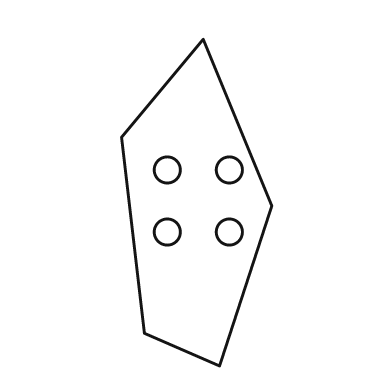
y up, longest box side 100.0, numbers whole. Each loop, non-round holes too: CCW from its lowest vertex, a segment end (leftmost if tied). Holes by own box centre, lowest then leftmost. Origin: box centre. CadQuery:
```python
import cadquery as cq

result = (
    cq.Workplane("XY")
    .moveTo(7.0, -50.0)
    .lineTo(23.0, -1.0)
    .lineTo(2.0, 50.0)
    .lineTo(-23.0, 20.0)
    .lineTo(-16.0, -40.0)
    .close()
    .moveTo(-9.0, -9.0)
    .circle(4.0)
    .moveTo(10.0, -9.0)
    .circle(4.0)
    .moveTo(-9.0, 10.0)
    .circle(4.0)
    .moveTo(10.0, 10.0)
    .circle(4.0)
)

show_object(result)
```